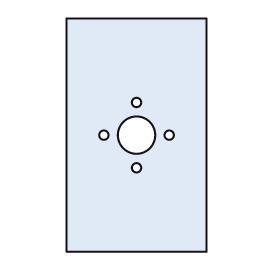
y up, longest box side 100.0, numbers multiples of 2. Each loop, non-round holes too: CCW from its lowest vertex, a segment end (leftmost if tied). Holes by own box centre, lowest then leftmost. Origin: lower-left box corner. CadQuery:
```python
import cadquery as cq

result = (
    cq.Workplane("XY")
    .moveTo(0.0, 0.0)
    .lineTo(60.0, 0.0)
    .lineTo(60.0, 100.0)
    .lineTo(0.0, 100.0)
    .close()
    .moveTo(30.0, 36.0)
    .circle(2.0)
    .moveTo(16.0, 50.0)
    .circle(2.0)
    .moveTo(30.0, 50.0)
    .circle(8.0)
    .moveTo(44.0, 50.0)
    .circle(2.0)
    .moveTo(30.0, 64.0)
    .circle(2.0)
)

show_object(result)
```